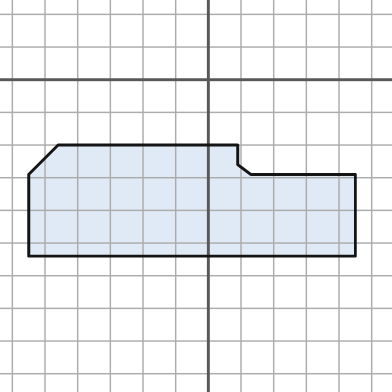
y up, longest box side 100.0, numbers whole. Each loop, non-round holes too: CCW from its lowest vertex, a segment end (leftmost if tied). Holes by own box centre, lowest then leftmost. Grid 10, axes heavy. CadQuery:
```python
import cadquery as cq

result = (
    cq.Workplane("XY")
    .moveTo(-55.0, -54.0)
    .lineTo(45.0, -54.0)
    .lineTo(45.0, -29.0)
    .lineTo(13.0, -29.0)
    .lineTo(9.0, -26.0)
    .lineTo(9.0, -20.0)
    .lineTo(-46.0, -20.0)
    .lineTo(-55.0, -29.0)
    .close()
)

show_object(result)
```